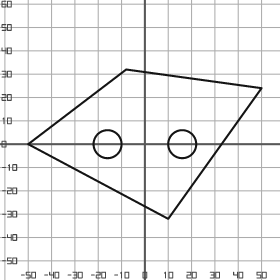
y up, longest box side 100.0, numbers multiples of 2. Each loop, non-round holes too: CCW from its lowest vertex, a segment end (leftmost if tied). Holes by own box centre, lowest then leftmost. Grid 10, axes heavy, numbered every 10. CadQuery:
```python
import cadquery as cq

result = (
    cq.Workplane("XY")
    .moveTo(10.0, -32.0)
    .lineTo(50.0, 24.0)
    .lineTo(-8.0, 32.0)
    .lineTo(-50.0, 0.0)
    .close()
    .moveTo(-16.0, 0.0)
    .circle(6.0)
    .moveTo(16.0, 0.0)
    .circle(6.0)
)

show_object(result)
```